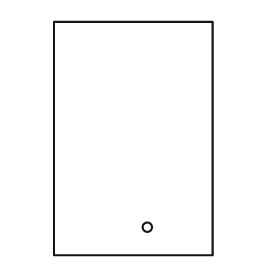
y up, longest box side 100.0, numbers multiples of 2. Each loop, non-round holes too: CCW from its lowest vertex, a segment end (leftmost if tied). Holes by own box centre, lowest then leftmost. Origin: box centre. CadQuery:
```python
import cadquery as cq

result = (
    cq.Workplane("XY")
    .moveTo(-34.0, -50.0)
    .lineTo(34.0, -50.0)
    .lineTo(34.0, 50.0)
    .lineTo(-34.0, 50.0)
    .close()
    .moveTo(6.0, -38.0)
    .circle(2.0)
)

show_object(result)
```